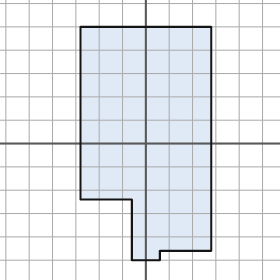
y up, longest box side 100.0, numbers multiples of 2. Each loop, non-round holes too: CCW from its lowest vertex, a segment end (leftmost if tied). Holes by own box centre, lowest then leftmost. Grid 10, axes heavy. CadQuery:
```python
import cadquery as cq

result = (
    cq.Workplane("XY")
    .moveTo(-6.0, -50.0)
    .lineTo(6.0, -50.0)
    .lineTo(6.0, -46.0)
    .lineTo(28.0, -46.0)
    .lineTo(28.0, 50.0)
    .lineTo(-28.0, 50.0)
    .lineTo(-28.0, -24.0)
    .lineTo(-6.0, -24.0)
    .close()
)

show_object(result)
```